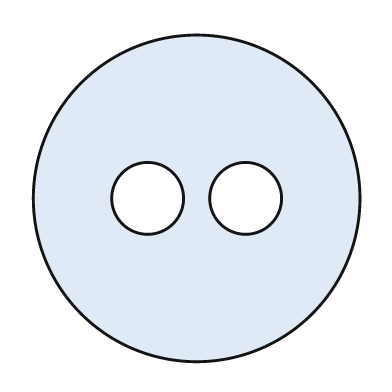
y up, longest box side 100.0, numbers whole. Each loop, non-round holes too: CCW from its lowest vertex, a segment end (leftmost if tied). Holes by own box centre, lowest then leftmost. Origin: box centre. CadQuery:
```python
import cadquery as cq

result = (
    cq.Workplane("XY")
    .moveTo(0.0, 0.0)
    .circle(50.0)
    .moveTo(-15.0, 0.0)
    .circle(11.0)
    .moveTo(15.0, 0.0)
    .circle(11.0)
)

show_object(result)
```